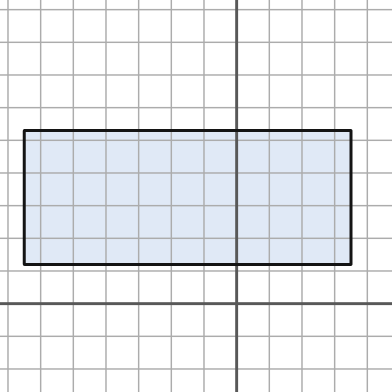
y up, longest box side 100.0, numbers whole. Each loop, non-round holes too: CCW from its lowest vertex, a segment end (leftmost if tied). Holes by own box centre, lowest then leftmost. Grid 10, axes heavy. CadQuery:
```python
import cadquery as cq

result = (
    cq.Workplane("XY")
    .moveTo(-65.0, 12.0)
    .lineTo(35.0, 12.0)
    .lineTo(35.0, 53.0)
    .lineTo(-65.0, 53.0)
    .close()
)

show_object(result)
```